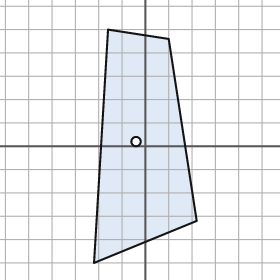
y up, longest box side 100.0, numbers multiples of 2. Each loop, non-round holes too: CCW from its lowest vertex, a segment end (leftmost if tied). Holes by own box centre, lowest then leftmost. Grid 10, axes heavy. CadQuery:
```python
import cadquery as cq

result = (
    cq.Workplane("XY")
    .moveTo(-22.0, -50.0)
    .lineTo(22.0, -32.0)
    .lineTo(10.0, 46.0)
    .lineTo(-16.0, 50.0)
    .close()
    .moveTo(-4.0, 2.0)
    .circle(2.0)
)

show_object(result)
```